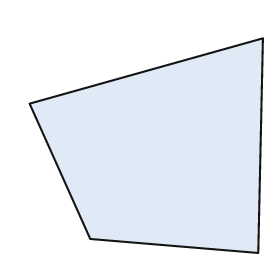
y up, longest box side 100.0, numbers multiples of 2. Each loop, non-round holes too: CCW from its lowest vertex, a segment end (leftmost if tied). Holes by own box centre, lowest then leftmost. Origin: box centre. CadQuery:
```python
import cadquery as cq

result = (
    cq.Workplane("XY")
    .moveTo(48.0, -46.0)
    .lineTo(50.0, 46.0)
    .lineTo(-50.0, 18.0)
    .lineTo(-24.0, -40.0)
    .close()
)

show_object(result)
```